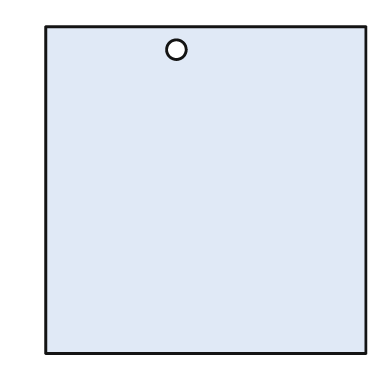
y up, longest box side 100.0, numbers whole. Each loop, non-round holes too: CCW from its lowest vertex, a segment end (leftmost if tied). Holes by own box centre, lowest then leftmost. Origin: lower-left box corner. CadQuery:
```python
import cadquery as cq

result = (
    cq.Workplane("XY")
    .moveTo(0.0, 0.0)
    .lineTo(98.0, 0.0)
    .lineTo(98.0, 100.0)
    .lineTo(0.0, 100.0)
    .close()
    .moveTo(40.0, 93.0)
    .circle(3.0)
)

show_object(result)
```